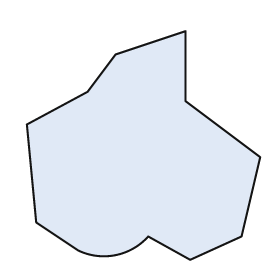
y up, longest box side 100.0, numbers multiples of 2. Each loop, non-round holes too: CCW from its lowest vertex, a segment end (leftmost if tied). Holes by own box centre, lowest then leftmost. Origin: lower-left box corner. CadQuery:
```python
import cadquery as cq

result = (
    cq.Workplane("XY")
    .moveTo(70.0, 0.0)
    .lineTo(92.0, 10.0)
    .lineTo(100.0, 44.0)
    .lineTo(68.0, 68.0)
    .lineTo(68.0, 98.0)
    .lineTo(38.0, 88.0)
    .lineTo(26.0, 72.0)
    .lineTo(0.0, 58.0)
    .lineTo(4.0, 16.0)
    .lineTo(22.0, 4.0)
    .threePointArc((38.0, 2.0), (52.0, 10.0))
    .close()
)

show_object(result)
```